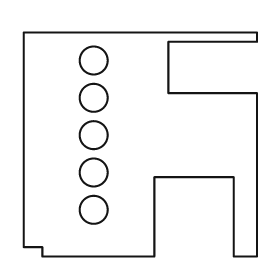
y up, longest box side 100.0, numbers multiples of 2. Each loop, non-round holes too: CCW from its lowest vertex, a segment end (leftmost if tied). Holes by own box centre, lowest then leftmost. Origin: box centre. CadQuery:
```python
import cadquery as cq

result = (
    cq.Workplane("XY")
    .moveTo(-42.0, -48.0)
    .lineTo(6.0, -48.0)
    .lineTo(6.0, -14.0)
    .lineTo(40.0, -14.0)
    .lineTo(40.0, -48.0)
    .lineTo(50.0, -48.0)
    .lineTo(50.0, 22.0)
    .lineTo(12.0, 22.0)
    .lineTo(12.0, 44.0)
    .lineTo(50.0, 44.0)
    .lineTo(50.0, 48.0)
    .lineTo(-50.0, 48.0)
    .lineTo(-50.0, -44.0)
    .lineTo(-42.0, -44.0)
    .close()
    .moveTo(-20.0, -28.0)
    .circle(6.0)
    .moveTo(-20.0, -12.0)
    .circle(6.0)
    .moveTo(-20.0, 4.0)
    .circle(6.0)
    .moveTo(-20.0, 20.0)
    .circle(6.0)
    .moveTo(-20.0, 36.0)
    .circle(6.0)
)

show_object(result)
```